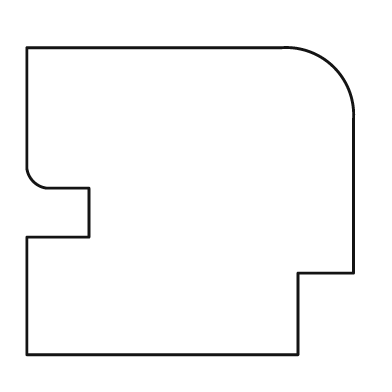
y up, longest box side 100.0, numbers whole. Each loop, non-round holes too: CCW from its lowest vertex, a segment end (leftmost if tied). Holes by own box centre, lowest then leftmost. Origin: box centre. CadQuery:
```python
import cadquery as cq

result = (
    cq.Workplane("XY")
    .moveTo(-50.0, -47.0)
    .lineTo(33.0, -47.0)
    .lineTo(33.0, -22.0)
    .lineTo(50.0, -22.0)
    .lineTo(50.0, 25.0)
    .threePointArc((44.0, 41.0), (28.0, 47.0))
    .lineTo(-50.0, 47.0)
    .lineTo(-50.0, 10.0)
    .threePointArc((-48.0, 6.0), (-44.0, 4.0))
    .lineTo(-31.0, 4.0)
    .lineTo(-31.0, -11.0)
    .lineTo(-50.0, -11.0)
    .close()
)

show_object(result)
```